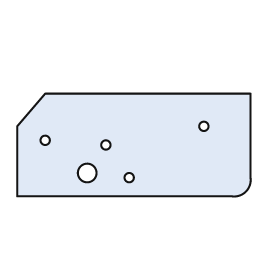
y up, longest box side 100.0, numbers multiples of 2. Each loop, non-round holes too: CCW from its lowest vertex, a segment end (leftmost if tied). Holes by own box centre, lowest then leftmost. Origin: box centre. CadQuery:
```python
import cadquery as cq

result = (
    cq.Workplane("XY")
    .moveTo(-50.0, -22.0)
    .lineTo(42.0, -22.0)
    .threePointArc((48.0, -20.0), (50.0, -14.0))
    .lineTo(50.0, 22.0)
    .lineTo(-38.0, 22.0)
    .lineTo(-50.0, 8.0)
    .close()
    .moveTo(-2.0, -14.0)
    .circle(2.0)
    .moveTo(-20.0, -12.0)
    .circle(4.0)
    .moveTo(-12.0, 0.0)
    .circle(2.0)
    .moveTo(-38.0, 2.0)
    .circle(2.0)
    .moveTo(30.0, 8.0)
    .circle(2.0)
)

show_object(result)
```